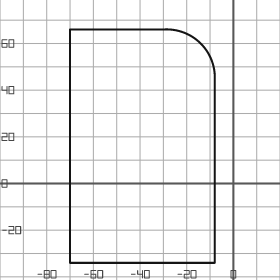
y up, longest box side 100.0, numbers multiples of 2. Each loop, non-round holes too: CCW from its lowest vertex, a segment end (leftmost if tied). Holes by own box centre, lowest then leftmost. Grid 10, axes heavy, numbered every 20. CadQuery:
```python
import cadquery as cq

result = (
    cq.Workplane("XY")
    .moveTo(-70.0, -34.0)
    .lineTo(-8.0, -34.0)
    .lineTo(-8.0, 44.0)
    .threePointArc((-14.0, 60.0), (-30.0, 66.0))
    .lineTo(-70.0, 66.0)
    .close()
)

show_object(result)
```